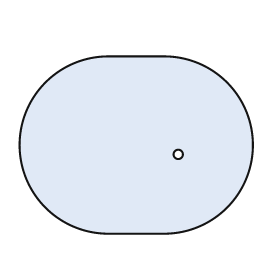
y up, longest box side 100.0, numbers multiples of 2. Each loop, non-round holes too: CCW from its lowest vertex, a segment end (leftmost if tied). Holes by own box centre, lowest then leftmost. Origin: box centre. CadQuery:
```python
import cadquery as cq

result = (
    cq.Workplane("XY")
    .moveTo(-12.0, -38.0)
    .lineTo(12.0, -38.0)
    .threePointArc((50.0, 0.0), (12.0, 38.0))
    .lineTo(-12.0, 38.0)
    .threePointArc((-50.0, 0.0), (-12.0, -38.0))
    .close()
    .moveTo(18.0, -4.0)
    .circle(2.0)
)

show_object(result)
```